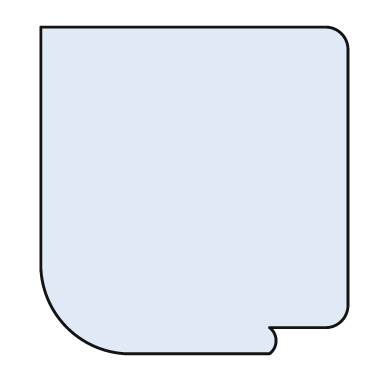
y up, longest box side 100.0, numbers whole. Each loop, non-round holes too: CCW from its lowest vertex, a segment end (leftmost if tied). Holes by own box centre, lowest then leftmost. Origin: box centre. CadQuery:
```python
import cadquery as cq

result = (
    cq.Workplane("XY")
    .moveTo(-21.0, -50.0)
    .lineTo(23.0, -50.0)
    .threePointArc((25.0, -46.0), (23.0, -42.0))
    .lineTo(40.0, -42.0)
    .threePointArc((45.0, -40.0), (47.0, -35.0))
    .lineTo(47.0, 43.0)
    .threePointArc((45.0, 48.0), (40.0, 50.0))
    .lineTo(-47.0, 50.0)
    .lineTo(-47.0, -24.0)
    .threePointArc((-39.0, -42.0), (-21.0, -50.0))
    .close()
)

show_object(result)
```